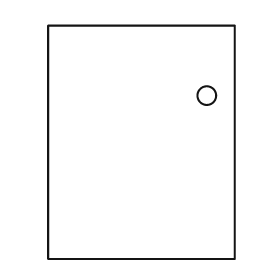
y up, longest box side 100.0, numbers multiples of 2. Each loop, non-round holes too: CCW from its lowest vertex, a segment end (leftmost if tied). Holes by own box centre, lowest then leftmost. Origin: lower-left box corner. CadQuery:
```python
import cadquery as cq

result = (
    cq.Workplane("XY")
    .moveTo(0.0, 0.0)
    .lineTo(80.0, 0.0)
    .lineTo(80.0, 100.0)
    .lineTo(0.0, 100.0)
    .close()
    .moveTo(68.0, 70.0)
    .circle(4.0)
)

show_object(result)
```